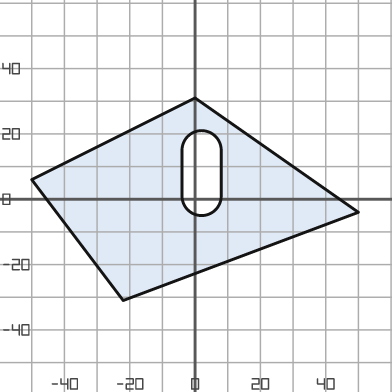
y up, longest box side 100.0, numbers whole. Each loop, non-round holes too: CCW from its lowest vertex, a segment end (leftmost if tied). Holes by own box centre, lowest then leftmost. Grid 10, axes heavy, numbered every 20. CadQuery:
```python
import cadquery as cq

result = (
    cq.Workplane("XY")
    .moveTo(-22.0, -31.0)
    .lineTo(50.0, -4.0)
    .lineTo(0.0, 31.0)
    .lineTo(-50.0, 6.0)
    .close()
    .moveTo(-4.0, 1.0)
    .threePointArc((2.0, -5.0), (8.0, 1.0))
    .lineTo(8.0, 15.0)
    .threePointArc((2.0, 21.0), (-4.0, 15.0))
    .close()
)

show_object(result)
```